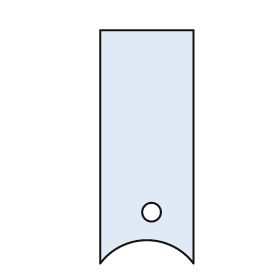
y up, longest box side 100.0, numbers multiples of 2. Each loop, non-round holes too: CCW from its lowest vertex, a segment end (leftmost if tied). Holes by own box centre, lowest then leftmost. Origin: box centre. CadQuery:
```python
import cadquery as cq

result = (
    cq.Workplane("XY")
    .moveTo(-20.0, -50.0)
    .threePointArc((0.0, -40.0), (20.0, -50.0))
    .lineTo(20.0, 50.0)
    .lineTo(-20.0, 50.0)
    .close()
    .moveTo(2.0, -28.0)
    .circle(4.0)
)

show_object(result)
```